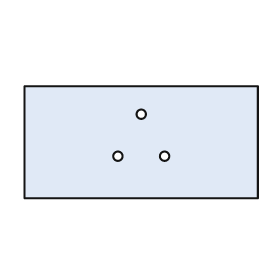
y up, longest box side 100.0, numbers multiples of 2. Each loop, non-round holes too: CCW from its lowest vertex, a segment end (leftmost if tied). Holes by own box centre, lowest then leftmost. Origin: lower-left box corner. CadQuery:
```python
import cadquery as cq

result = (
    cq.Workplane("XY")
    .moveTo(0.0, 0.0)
    .lineTo(100.0, 0.0)
    .lineTo(100.0, 48.0)
    .lineTo(0.0, 48.0)
    .close()
    .moveTo(40.0, 18.0)
    .circle(2.0)
    .moveTo(60.0, 18.0)
    .circle(2.0)
    .moveTo(50.0, 36.0)
    .circle(2.0)
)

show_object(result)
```